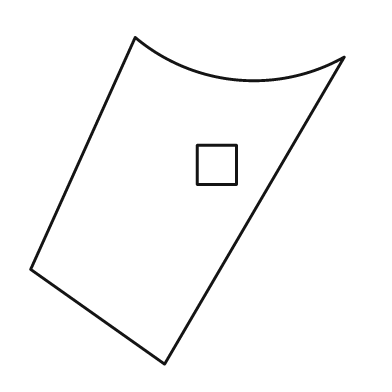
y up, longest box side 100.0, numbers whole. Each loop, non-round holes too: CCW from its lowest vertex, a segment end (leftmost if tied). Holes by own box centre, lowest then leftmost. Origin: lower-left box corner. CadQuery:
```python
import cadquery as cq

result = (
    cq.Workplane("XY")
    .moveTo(41.0, 0.0)
    .lineTo(96.0, 94.0)
    .threePointArc((63.0, 87.0), (32.0, 100.0))
    .lineTo(0.0, 29.0)
    .close()
    .moveTo(51.0, 55.0)
    .lineTo(63.0, 55.0)
    .lineTo(63.0, 67.0)
    .lineTo(51.0, 67.0)
    .close()
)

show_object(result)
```